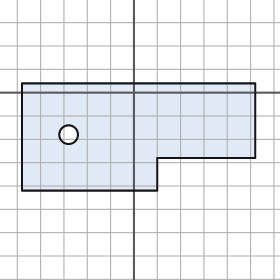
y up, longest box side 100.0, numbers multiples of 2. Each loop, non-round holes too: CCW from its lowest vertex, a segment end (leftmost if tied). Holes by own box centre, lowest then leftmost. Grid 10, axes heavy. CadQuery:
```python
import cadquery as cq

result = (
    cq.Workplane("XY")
    .moveTo(-48.0, -42.0)
    .lineTo(10.0, -42.0)
    .lineTo(10.0, -28.0)
    .lineTo(52.0, -28.0)
    .lineTo(52.0, 4.0)
    .lineTo(-48.0, 4.0)
    .close()
    .moveTo(-28.0, -18.0)
    .circle(4.0)
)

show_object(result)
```